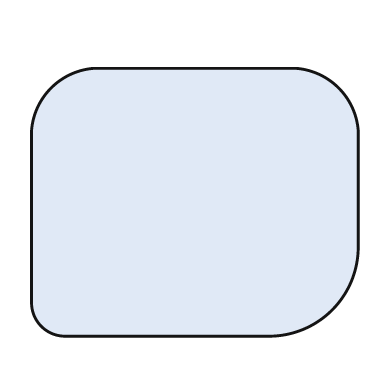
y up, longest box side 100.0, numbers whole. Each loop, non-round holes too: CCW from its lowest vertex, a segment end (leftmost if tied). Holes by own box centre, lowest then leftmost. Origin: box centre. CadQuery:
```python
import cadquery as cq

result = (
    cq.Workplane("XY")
    .moveTo(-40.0, -41.0)
    .lineTo(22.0, -41.0)
    .threePointArc((42.0, -33.0), (50.0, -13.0))
    .lineTo(50.0, 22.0)
    .threePointArc((44.0, 35.0), (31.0, 41.0))
    .lineTo(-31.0, 41.0)
    .threePointArc((-44.0, 35.0), (-50.0, 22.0))
    .lineTo(-50.0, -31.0)
    .threePointArc((-47.0, -38.0), (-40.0, -41.0))
    .close()
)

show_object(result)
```